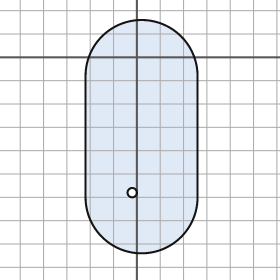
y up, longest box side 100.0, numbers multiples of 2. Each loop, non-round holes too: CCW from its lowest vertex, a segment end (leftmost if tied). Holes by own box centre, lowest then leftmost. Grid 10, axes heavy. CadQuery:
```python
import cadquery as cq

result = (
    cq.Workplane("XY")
    .moveTo(-22.0, -60.0)
    .threePointArc((2.0, -84.0), (26.0, -60.0))
    .lineTo(26.0, -8.0)
    .threePointArc((2.0, 16.0), (-22.0, -8.0))
    .close()
    .moveTo(-2.0, -58.0)
    .circle(2.0)
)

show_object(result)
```